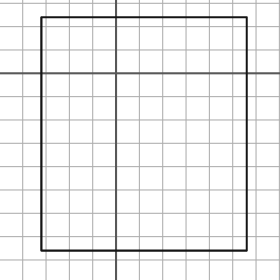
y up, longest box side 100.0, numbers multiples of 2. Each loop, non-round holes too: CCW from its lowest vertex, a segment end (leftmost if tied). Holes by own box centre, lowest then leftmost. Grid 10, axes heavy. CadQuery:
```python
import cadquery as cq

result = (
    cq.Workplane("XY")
    .moveTo(-32.0, -76.0)
    .lineTo(56.0, -76.0)
    .lineTo(56.0, 24.0)
    .lineTo(-32.0, 24.0)
    .close()
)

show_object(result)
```